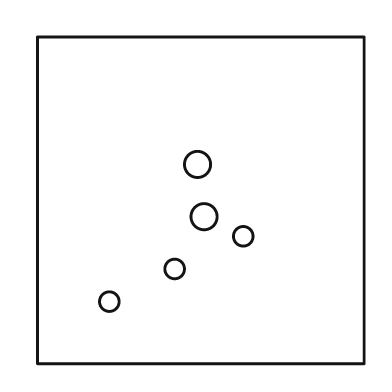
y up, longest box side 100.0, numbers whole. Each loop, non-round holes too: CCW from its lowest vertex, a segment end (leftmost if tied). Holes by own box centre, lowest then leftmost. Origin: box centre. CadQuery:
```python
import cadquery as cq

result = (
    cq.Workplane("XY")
    .moveTo(-50.0, -50.0)
    .lineTo(50.0, -50.0)
    .lineTo(50.0, 50.0)
    .lineTo(-50.0, 50.0)
    .close()
    .moveTo(-28.0, -31.0)
    .circle(3.0)
    .moveTo(-8.0, -21.0)
    .circle(3.0)
    .moveTo(13.0, -11.0)
    .circle(3.0)
    .moveTo(1.0, -5.0)
    .circle(4.0)
    .moveTo(-1.0, 11.0)
    .circle(4.0)
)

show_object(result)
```